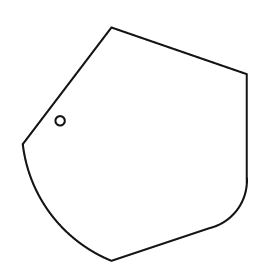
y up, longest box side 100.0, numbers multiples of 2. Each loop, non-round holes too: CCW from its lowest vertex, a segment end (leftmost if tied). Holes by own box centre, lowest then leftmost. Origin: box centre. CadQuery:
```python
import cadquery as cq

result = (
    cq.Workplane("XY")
    .moveTo(-10.0, -50.0)
    .lineTo(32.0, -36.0)
    .threePointArc((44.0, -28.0), (48.0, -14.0))
    .lineTo(48.0, 30.0)
    .lineTo(-10.0, 50.0)
    .lineTo(-48.0, 0.0)
    .threePointArc((-36.0, -30.0), (-10.0, -50.0))
    .close()
    .moveTo(-32.0, 10.0)
    .circle(2.0)
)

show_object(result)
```